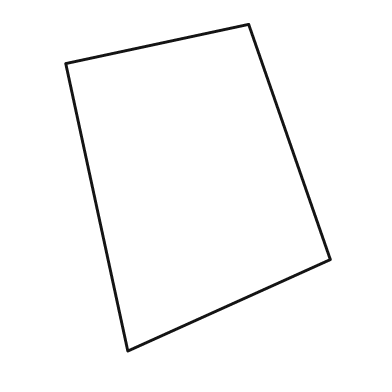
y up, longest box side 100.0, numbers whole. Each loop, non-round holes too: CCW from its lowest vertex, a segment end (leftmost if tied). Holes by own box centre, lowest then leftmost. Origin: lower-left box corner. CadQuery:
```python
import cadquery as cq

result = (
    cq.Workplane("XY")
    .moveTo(19.0, 0.0)
    .lineTo(81.0, 28.0)
    .lineTo(56.0, 100.0)
    .lineTo(0.0, 88.0)
    .close()
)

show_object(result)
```